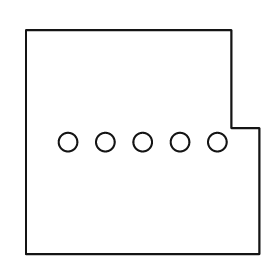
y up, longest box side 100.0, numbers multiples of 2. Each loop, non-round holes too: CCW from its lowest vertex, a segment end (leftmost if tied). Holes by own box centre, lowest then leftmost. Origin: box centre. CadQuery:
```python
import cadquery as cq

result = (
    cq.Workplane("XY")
    .moveTo(-50.0, -48.0)
    .lineTo(50.0, -48.0)
    .lineTo(50.0, 6.0)
    .lineTo(38.0, 6.0)
    .lineTo(38.0, 48.0)
    .lineTo(-50.0, 48.0)
    .close()
    .moveTo(-32.0, 0.0)
    .circle(4.0)
    .moveTo(-16.0, 0.0)
    .circle(4.0)
    .moveTo(0.0, 0.0)
    .circle(4.0)
    .moveTo(16.0, 0.0)
    .circle(4.0)
    .moveTo(32.0, 0.0)
    .circle(4.0)
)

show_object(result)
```